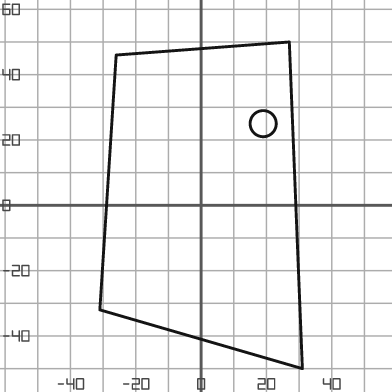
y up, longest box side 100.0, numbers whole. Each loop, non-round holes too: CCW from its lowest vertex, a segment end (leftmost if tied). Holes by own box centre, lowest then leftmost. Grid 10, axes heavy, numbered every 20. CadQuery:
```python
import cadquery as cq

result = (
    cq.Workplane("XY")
    .moveTo(31.0, -50.0)
    .lineTo(27.0, 50.0)
    .lineTo(-26.0, 46.0)
    .lineTo(-31.0, -32.0)
    .close()
    .moveTo(19.0, 25.0)
    .circle(4.0)
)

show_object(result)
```